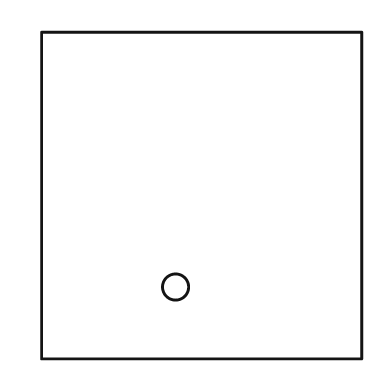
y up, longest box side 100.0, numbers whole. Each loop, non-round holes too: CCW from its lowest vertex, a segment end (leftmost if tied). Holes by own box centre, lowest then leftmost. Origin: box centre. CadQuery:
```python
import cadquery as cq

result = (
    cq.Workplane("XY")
    .moveTo(-49.0, -50.0)
    .lineTo(49.0, -50.0)
    .lineTo(49.0, 50.0)
    .lineTo(-49.0, 50.0)
    .close()
    .moveTo(-8.0, -28.0)
    .circle(4.0)
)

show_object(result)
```